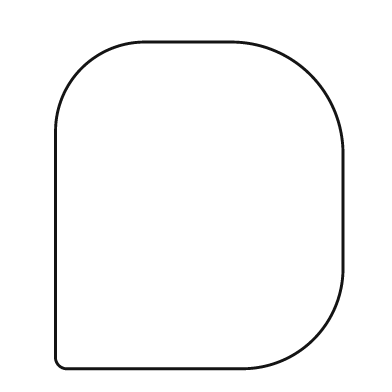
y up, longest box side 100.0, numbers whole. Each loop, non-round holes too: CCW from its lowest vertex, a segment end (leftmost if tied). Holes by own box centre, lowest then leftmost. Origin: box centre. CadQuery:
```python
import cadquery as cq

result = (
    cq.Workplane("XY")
    .moveTo(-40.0, -50.0)
    .lineTo(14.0, -50.0)
    .threePointArc((35.0, -41.0), (44.0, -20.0))
    .lineTo(44.0, 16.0)
    .threePointArc((34.0, 40.0), (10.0, 50.0))
    .lineTo(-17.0, 50.0)
    .threePointArc((-36.0, 42.0), (-44.0, 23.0))
    .lineTo(-44.0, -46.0)
    .threePointArc((-43.0, -49.0), (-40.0, -50.0))
    .close()
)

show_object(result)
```